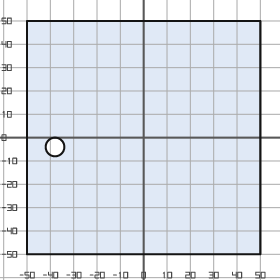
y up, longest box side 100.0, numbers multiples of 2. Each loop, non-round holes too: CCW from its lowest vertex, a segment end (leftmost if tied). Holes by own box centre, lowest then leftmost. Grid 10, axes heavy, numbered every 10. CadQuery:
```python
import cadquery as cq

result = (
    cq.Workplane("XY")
    .moveTo(-50.0, -50.0)
    .lineTo(50.0, -50.0)
    .lineTo(50.0, 50.0)
    .lineTo(-50.0, 50.0)
    .close()
    .moveTo(-38.0, -4.0)
    .circle(4.0)
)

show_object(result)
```